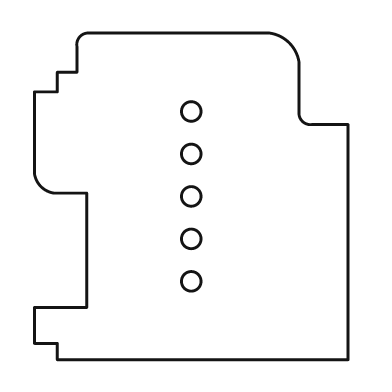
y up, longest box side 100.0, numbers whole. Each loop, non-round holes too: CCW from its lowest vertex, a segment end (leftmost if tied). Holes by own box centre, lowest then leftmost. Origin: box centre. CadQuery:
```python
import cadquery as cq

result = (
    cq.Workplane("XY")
    .moveTo(-41.0, -50.0)
    .lineTo(48.0, -50.0)
    .lineTo(48.0, 22.0)
    .lineTo(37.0, 22.0)
    .threePointArc((34.0, 23.0), (33.0, 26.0))
    .lineTo(33.0, 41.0)
    .threePointArc((30.0, 47.0), (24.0, 50.0))
    .lineTo(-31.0, 50.0)
    .threePointArc((-34.0, 49.0), (-35.0, 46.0))
    .lineTo(-35.0, 38.0)
    .lineTo(-41.0, 38.0)
    .lineTo(-41.0, 32.0)
    .lineTo(-48.0, 32.0)
    .lineTo(-48.0, 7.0)
    .threePointArc((-46.0, 3.0), (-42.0, 1.0))
    .lineTo(-32.0, 1.0)
    .lineTo(-32.0, -34.0)
    .lineTo(-48.0, -34.0)
    .lineTo(-48.0, -45.0)
    .lineTo(-41.0, -45.0)
    .close()
    .moveTo(0.0, -26.0)
    .circle(3.0)
    .moveTo(0.0, -13.0)
    .circle(3.0)
    .moveTo(0.0, 0.0)
    .circle(3.0)
    .moveTo(0.0, 13.0)
    .circle(3.0)
    .moveTo(0.0, 26.0)
    .circle(3.0)
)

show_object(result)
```